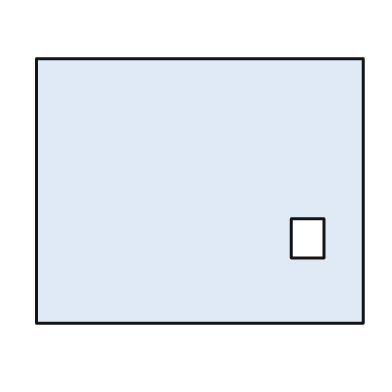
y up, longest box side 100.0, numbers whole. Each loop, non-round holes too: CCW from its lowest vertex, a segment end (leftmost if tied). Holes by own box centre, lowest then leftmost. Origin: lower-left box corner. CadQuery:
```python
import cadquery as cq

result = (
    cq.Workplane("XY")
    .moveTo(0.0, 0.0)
    .lineTo(100.0, 0.0)
    .lineTo(100.0, 81.0)
    .lineTo(0.0, 81.0)
    .close()
    .moveTo(78.0, 20.0)
    .lineTo(88.0, 20.0)
    .lineTo(88.0, 32.0)
    .lineTo(78.0, 32.0)
    .close()
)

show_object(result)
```